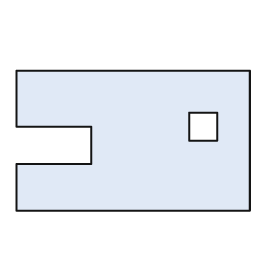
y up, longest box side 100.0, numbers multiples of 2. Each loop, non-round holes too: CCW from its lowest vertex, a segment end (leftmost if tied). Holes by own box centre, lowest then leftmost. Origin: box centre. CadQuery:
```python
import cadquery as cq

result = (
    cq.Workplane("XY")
    .moveTo(-50.0, -30.0)
    .lineTo(50.0, -30.0)
    .lineTo(50.0, 30.0)
    .lineTo(-50.0, 30.0)
    .lineTo(-50.0, 6.0)
    .lineTo(-18.0, 6.0)
    .lineTo(-18.0, -10.0)
    .lineTo(-50.0, -10.0)
    .close()
    .moveTo(24.0, 0.0)
    .lineTo(36.0, 0.0)
    .lineTo(36.0, 12.0)
    .lineTo(24.0, 12.0)
    .close()
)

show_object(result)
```